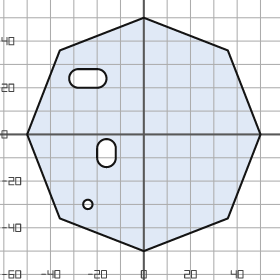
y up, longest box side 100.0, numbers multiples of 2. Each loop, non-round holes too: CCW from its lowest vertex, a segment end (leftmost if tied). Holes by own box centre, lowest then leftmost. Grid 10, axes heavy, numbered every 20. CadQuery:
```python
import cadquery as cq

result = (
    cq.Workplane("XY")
    .moveTo(0.0, -50.0)
    .lineTo(36.0, -36.0)
    .lineTo(50.0, 0.0)
    .lineTo(36.0, 36.0)
    .lineTo(0.0, 50.0)
    .lineTo(-36.0, 36.0)
    .lineTo(-50.0, 0.0)
    .lineTo(-36.0, -36.0)
    .close()
    .moveTo(-24.0, -30.0)
    .circle(2.0)
    .moveTo(-20.0, -10.0)
    .threePointArc((-16.0, -14.0), (-12.0, -10.0))
    .lineTo(-12.0, -6.0)
    .threePointArc((-16.0, -2.0), (-20.0, -6.0))
    .close()
    .moveTo(-28.0, 20.0)
    .lineTo(-20.0, 20.0)
    .threePointArc((-16.0, 24.0), (-20.0, 28.0))
    .lineTo(-28.0, 28.0)
    .threePointArc((-32.0, 24.0), (-28.0, 20.0))
    .close()
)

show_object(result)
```